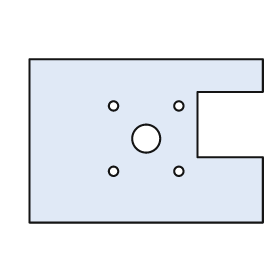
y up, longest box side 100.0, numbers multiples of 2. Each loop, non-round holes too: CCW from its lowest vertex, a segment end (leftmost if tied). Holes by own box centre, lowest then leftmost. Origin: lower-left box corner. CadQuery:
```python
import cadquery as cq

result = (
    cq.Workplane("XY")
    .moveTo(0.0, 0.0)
    .lineTo(100.0, 0.0)
    .lineTo(100.0, 28.0)
    .lineTo(72.0, 28.0)
    .lineTo(72.0, 56.0)
    .lineTo(100.0, 56.0)
    .lineTo(100.0, 70.0)
    .lineTo(0.0, 70.0)
    .close()
    .moveTo(36.0, 22.0)
    .circle(2.0)
    .moveTo(64.0, 22.0)
    .circle(2.0)
    .moveTo(50.0, 36.0)
    .circle(6.0)
    .moveTo(36.0, 50.0)
    .circle(2.0)
    .moveTo(64.0, 50.0)
    .circle(2.0)
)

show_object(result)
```